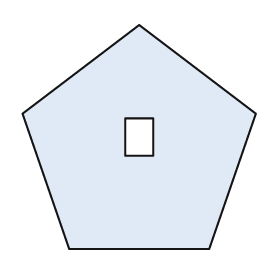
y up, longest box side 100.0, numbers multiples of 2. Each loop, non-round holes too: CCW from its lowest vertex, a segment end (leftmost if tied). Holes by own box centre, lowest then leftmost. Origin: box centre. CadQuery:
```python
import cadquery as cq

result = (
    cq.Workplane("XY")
    .moveTo(-30.0, -48.0)
    .lineTo(30.0, -48.0)
    .lineTo(50.0, 10.0)
    .lineTo(0.0, 48.0)
    .lineTo(-50.0, 10.0)
    .close()
    .moveTo(-6.0, -8.0)
    .lineTo(6.0, -8.0)
    .lineTo(6.0, 8.0)
    .lineTo(-6.0, 8.0)
    .close()
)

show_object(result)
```